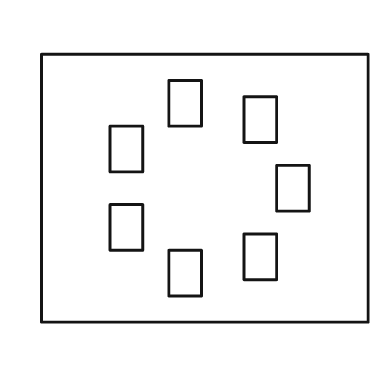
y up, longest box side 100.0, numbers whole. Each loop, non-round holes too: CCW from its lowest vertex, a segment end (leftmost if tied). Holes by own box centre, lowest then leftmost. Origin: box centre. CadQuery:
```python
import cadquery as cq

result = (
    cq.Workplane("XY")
    .moveTo(-50.0, -41.0)
    .lineTo(50.0, -41.0)
    .lineTo(50.0, 41.0)
    .lineTo(-50.0, 41.0)
    .close()
    .moveTo(-11.0, -33.0)
    .lineTo(-1.0, -33.0)
    .lineTo(-1.0, -19.0)
    .lineTo(-11.0, -19.0)
    .close()
    .moveTo(12.0, -28.0)
    .lineTo(22.0, -28.0)
    .lineTo(22.0, -14.0)
    .lineTo(12.0, -14.0)
    .close()
    .moveTo(-29.0, -19.0)
    .lineTo(-19.0, -19.0)
    .lineTo(-19.0, -5.0)
    .lineTo(-29.0, -5.0)
    .close()
    .moveTo(22.0, -7.0)
    .lineTo(32.0, -7.0)
    .lineTo(32.0, 7.0)
    .lineTo(22.0, 7.0)
    .close()
    .moveTo(-29.0, 5.0)
    .lineTo(-19.0, 5.0)
    .lineTo(-19.0, 19.0)
    .lineTo(-29.0, 19.0)
    .close()
    .moveTo(12.0, 14.0)
    .lineTo(22.0, 14.0)
    .lineTo(22.0, 28.0)
    .lineTo(12.0, 28.0)
    .close()
    .moveTo(-11.0, 19.0)
    .lineTo(-1.0, 19.0)
    .lineTo(-1.0, 33.0)
    .lineTo(-11.0, 33.0)
    .close()
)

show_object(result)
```